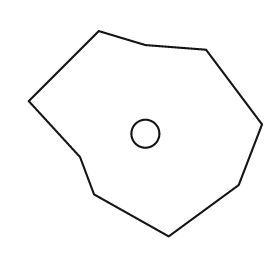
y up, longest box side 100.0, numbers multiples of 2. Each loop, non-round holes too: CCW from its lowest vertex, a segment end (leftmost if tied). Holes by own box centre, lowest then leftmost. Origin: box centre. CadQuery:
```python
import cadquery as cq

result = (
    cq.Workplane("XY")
    .moveTo(10.0, -44.0)
    .lineTo(40.0, -22.0)
    .lineTo(50.0, 4.0)
    .lineTo(26.0, 36.0)
    .lineTo(0.0, 38.0)
    .lineTo(-20.0, 44.0)
    .lineTo(-50.0, 14.0)
    .lineTo(-28.0, -10.0)
    .lineTo(-22.0, -26.0)
    .close()
    .moveTo(0.0, 0.0)
    .circle(6.0)
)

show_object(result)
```